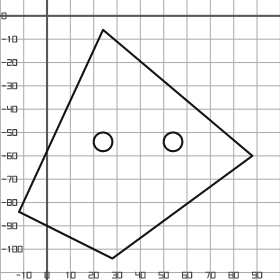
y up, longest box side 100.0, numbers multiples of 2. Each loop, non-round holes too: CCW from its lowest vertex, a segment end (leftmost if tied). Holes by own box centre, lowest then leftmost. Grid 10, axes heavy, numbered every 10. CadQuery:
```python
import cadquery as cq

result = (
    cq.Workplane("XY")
    .moveTo(28.0, -104.0)
    .lineTo(88.0, -60.0)
    .lineTo(24.0, -6.0)
    .lineTo(-12.0, -84.0)
    .close()
    .moveTo(24.0, -54.0)
    .circle(4.0)
    .moveTo(54.0, -54.0)
    .circle(4.0)
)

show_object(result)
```